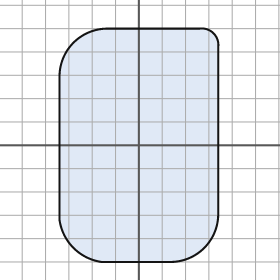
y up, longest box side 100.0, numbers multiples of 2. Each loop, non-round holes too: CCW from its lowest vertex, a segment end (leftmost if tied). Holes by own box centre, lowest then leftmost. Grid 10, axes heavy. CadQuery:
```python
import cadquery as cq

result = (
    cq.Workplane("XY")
    .moveTo(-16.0, -50.0)
    .lineTo(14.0, -50.0)
    .threePointArc((28.0, -44.0), (34.0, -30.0))
    .lineTo(34.0, 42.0)
    .threePointArc((32.0, 48.0), (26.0, 50.0))
    .lineTo(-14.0, 50.0)
    .threePointArc((-28.0, 44.0), (-34.0, 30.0))
    .lineTo(-34.0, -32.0)
    .threePointArc((-28.0, -44.0), (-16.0, -50.0))
    .close()
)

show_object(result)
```